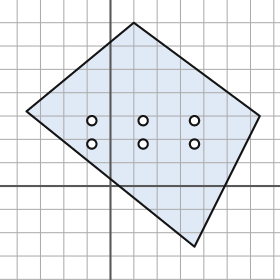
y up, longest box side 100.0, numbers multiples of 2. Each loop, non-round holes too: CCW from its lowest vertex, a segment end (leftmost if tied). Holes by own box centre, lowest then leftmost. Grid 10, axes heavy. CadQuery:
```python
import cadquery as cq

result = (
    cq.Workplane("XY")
    .moveTo(36.0, -26.0)
    .lineTo(64.0, 30.0)
    .lineTo(10.0, 70.0)
    .lineTo(-36.0, 32.0)
    .close()
    .moveTo(-8.0, 18.0)
    .circle(2.0)
    .moveTo(14.0, 18.0)
    .circle(2.0)
    .moveTo(36.0, 18.0)
    .circle(2.0)
    .moveTo(-8.0, 28.0)
    .circle(2.0)
    .moveTo(14.0, 28.0)
    .circle(2.0)
    .moveTo(36.0, 28.0)
    .circle(2.0)
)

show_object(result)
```